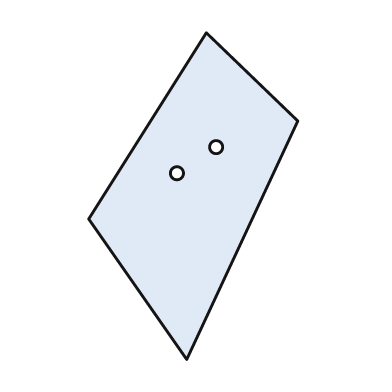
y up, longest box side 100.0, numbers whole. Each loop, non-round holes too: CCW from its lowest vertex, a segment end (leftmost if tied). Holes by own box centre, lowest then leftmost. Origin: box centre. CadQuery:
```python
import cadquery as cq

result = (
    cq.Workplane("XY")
    .moveTo(-2.0, -50.0)
    .lineTo(32.0, 23.0)
    .lineTo(4.0, 50.0)
    .lineTo(-32.0, -7.0)
    .close()
    .moveTo(-5.0, 7.0)
    .circle(2.0)
    .moveTo(7.0, 15.0)
    .circle(2.0)
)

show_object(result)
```